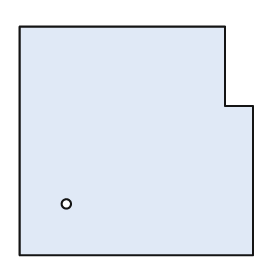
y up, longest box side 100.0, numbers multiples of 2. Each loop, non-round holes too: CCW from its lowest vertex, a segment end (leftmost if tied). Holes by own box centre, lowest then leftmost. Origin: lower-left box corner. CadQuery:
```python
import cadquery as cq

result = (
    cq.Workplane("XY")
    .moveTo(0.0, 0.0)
    .lineTo(100.0, 0.0)
    .lineTo(100.0, 64.0)
    .lineTo(88.0, 64.0)
    .lineTo(88.0, 98.0)
    .lineTo(0.0, 98.0)
    .close()
    .moveTo(20.0, 22.0)
    .circle(2.0)
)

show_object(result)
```